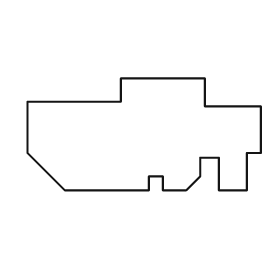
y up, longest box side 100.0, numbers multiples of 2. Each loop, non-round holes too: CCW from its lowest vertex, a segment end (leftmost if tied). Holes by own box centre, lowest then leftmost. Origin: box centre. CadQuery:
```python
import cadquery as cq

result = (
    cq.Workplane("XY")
    .moveTo(-34.0, -24.0)
    .lineTo(2.0, -24.0)
    .lineTo(2.0, -18.0)
    .lineTo(8.0, -18.0)
    .lineTo(8.0, -24.0)
    .lineTo(18.0, -24.0)
    .lineTo(24.0, -18.0)
    .lineTo(24.0, -10.0)
    .lineTo(32.0, -10.0)
    .lineTo(32.0, -24.0)
    .lineTo(44.0, -24.0)
    .lineTo(44.0, -8.0)
    .lineTo(50.0, -8.0)
    .lineTo(50.0, 12.0)
    .lineTo(26.0, 12.0)
    .lineTo(26.0, 24.0)
    .lineTo(-10.0, 24.0)
    .lineTo(-10.0, 14.0)
    .lineTo(-50.0, 14.0)
    .lineTo(-50.0, -8.0)
    .close()
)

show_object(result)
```